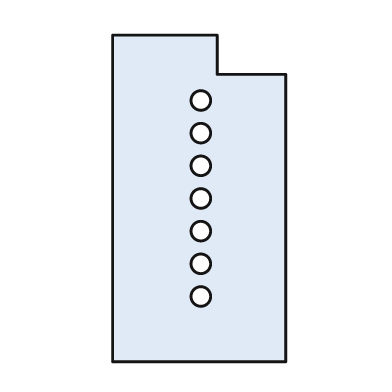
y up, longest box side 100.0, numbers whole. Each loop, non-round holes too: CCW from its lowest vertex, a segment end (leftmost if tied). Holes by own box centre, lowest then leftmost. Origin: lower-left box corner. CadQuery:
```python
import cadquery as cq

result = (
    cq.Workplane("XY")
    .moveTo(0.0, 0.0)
    .lineTo(53.0, 0.0)
    .lineTo(53.0, 88.0)
    .lineTo(32.0, 88.0)
    .lineTo(32.0, 100.0)
    .lineTo(0.0, 100.0)
    .close()
    .moveTo(27.0, 20.0)
    .circle(3.0)
    .moveTo(27.0, 30.0)
    .circle(3.0)
    .moveTo(27.0, 40.0)
    .circle(3.0)
    .moveTo(27.0, 50.0)
    .circle(3.0)
    .moveTo(27.0, 60.0)
    .circle(3.0)
    .moveTo(27.0, 70.0)
    .circle(3.0)
    .moveTo(27.0, 80.0)
    .circle(3.0)
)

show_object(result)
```